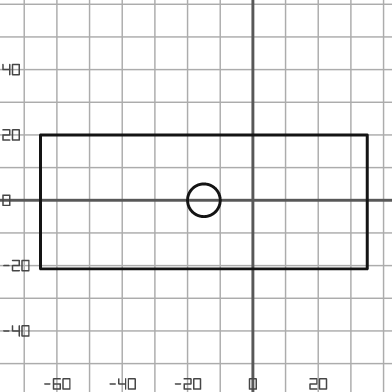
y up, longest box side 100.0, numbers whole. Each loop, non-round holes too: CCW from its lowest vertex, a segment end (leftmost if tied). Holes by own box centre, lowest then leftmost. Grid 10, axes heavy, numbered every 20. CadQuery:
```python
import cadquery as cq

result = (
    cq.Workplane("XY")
    .moveTo(-65.0, -21.0)
    .lineTo(35.0, -21.0)
    .lineTo(35.0, 20.0)
    .lineTo(-65.0, 20.0)
    .close()
    .moveTo(-15.0, 0.0)
    .circle(5.0)
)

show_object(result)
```